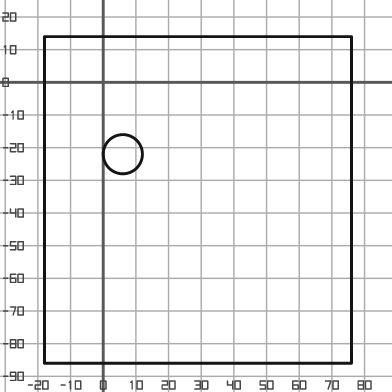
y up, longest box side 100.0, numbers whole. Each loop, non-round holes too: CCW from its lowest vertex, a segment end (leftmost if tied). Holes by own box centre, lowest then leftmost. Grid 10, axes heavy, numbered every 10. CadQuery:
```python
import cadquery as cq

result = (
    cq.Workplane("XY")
    .moveTo(-18.0, -86.0)
    .lineTo(76.0, -86.0)
    .lineTo(76.0, 14.0)
    .lineTo(-18.0, 14.0)
    .close()
    .moveTo(6.0, -22.0)
    .circle(6.0)
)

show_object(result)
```